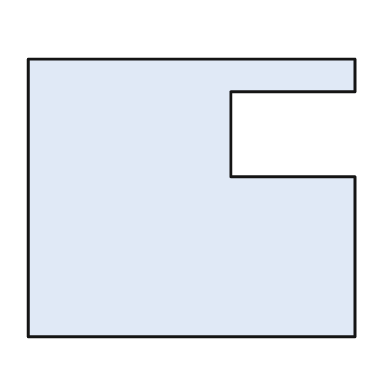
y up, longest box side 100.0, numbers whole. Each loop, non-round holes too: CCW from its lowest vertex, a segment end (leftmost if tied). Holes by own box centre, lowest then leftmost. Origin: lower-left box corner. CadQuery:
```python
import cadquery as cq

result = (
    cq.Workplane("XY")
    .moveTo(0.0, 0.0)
    .lineTo(100.0, 0.0)
    .lineTo(100.0, 49.0)
    .lineTo(62.0, 49.0)
    .lineTo(62.0, 75.0)
    .lineTo(100.0, 75.0)
    .lineTo(100.0, 85.0)
    .lineTo(0.0, 85.0)
    .close()
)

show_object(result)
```